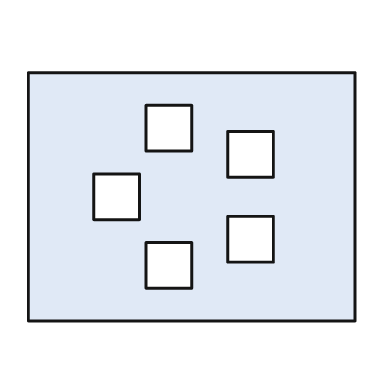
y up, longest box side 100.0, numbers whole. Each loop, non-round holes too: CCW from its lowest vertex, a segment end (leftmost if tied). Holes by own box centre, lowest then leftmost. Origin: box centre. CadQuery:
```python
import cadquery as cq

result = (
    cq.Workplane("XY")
    .moveTo(-50.0, -38.0)
    .lineTo(50.0, -38.0)
    .lineTo(50.0, 38.0)
    .lineTo(-50.0, 38.0)
    .close()
    .moveTo(-14.0, -28.0)
    .lineTo(0.0, -28.0)
    .lineTo(0.0, -14.0)
    .lineTo(-14.0, -14.0)
    .close()
    .moveTo(11.0, -20.0)
    .lineTo(25.0, -20.0)
    .lineTo(25.0, -6.0)
    .lineTo(11.0, -6.0)
    .close()
    .moveTo(-30.0, -7.0)
    .lineTo(-16.0, -7.0)
    .lineTo(-16.0, 7.0)
    .lineTo(-30.0, 7.0)
    .close()
    .moveTo(11.0, 6.0)
    .lineTo(25.0, 6.0)
    .lineTo(25.0, 20.0)
    .lineTo(11.0, 20.0)
    .close()
    .moveTo(-14.0, 14.0)
    .lineTo(0.0, 14.0)
    .lineTo(0.0, 28.0)
    .lineTo(-14.0, 28.0)
    .close()
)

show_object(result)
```